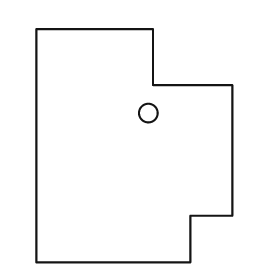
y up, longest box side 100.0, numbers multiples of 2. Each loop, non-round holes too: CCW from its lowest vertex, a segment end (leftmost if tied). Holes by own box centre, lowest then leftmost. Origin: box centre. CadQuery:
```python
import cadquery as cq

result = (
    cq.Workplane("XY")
    .moveTo(-42.0, -50.0)
    .lineTo(24.0, -50.0)
    .lineTo(24.0, -30.0)
    .lineTo(42.0, -30.0)
    .lineTo(42.0, 26.0)
    .lineTo(8.0, 26.0)
    .lineTo(8.0, 50.0)
    .lineTo(-42.0, 50.0)
    .close()
    .moveTo(6.0, 14.0)
    .circle(4.0)
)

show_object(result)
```